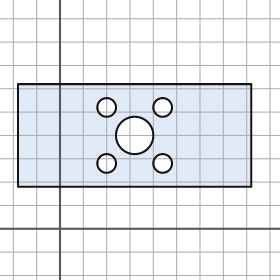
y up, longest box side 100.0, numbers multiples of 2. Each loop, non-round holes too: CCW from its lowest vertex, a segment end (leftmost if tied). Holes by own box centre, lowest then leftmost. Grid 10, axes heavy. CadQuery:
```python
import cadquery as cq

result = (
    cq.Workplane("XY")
    .moveTo(-18.0, 18.0)
    .lineTo(82.0, 18.0)
    .lineTo(82.0, 62.0)
    .lineTo(-18.0, 62.0)
    .close()
    .moveTo(20.0, 28.0)
    .circle(4.0)
    .moveTo(44.0, 28.0)
    .circle(4.0)
    .moveTo(32.0, 40.0)
    .circle(8.0)
    .moveTo(20.0, 52.0)
    .circle(4.0)
    .moveTo(44.0, 52.0)
    .circle(4.0)
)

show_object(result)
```